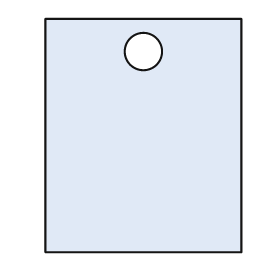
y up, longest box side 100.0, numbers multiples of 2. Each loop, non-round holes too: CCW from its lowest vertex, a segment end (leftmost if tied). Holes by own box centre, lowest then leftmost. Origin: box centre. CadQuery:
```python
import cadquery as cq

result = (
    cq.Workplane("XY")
    .moveTo(-42.0, -50.0)
    .lineTo(42.0, -50.0)
    .lineTo(42.0, 50.0)
    .lineTo(-42.0, 50.0)
    .close()
    .moveTo(0.0, 36.0)
    .circle(8.0)
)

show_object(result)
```